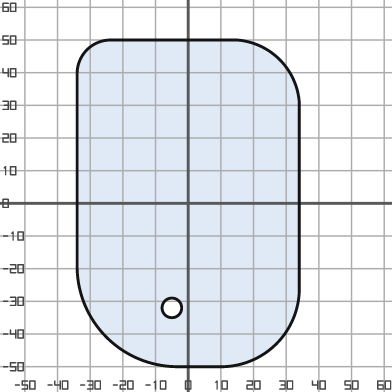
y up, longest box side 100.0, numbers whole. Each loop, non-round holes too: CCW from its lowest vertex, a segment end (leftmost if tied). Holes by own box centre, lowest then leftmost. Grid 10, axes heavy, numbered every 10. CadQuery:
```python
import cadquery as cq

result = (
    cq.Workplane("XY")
    .moveTo(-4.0, -50.0)
    .lineTo(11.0, -50.0)
    .threePointArc((27.0, -43.0), (34.0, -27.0))
    .lineTo(34.0, 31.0)
    .threePointArc((28.0, 44.0), (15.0, 50.0))
    .lineTo(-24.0, 50.0)
    .threePointArc((-31.0, 47.0), (-34.0, 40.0))
    .lineTo(-34.0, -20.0)
    .threePointArc((-25.0, -41.0), (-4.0, -50.0))
    .close()
    .moveTo(-5.0, -32.0)
    .circle(3.0)
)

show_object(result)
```